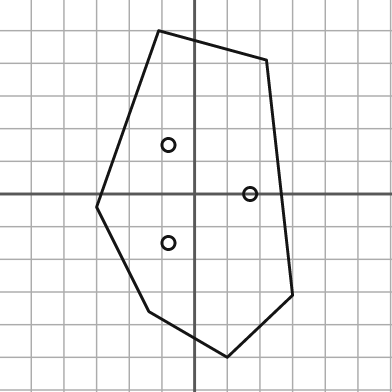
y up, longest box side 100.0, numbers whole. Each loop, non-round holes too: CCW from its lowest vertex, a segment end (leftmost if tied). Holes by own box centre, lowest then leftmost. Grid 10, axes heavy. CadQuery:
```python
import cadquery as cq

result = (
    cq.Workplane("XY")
    .moveTo(10.0, -50.0)
    .lineTo(30.0, -31.0)
    .lineTo(22.0, 41.0)
    .lineTo(-11.0, 50.0)
    .lineTo(-30.0, -4.0)
    .lineTo(-14.0, -36.0)
    .close()
    .moveTo(-8.0, -15.0)
    .circle(2.0)
    .moveTo(17.0, 0.0)
    .circle(2.0)
    .moveTo(-8.0, 15.0)
    .circle(2.0)
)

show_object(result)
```